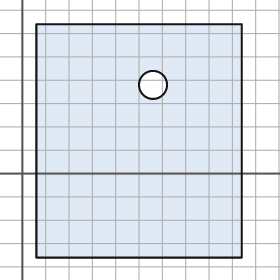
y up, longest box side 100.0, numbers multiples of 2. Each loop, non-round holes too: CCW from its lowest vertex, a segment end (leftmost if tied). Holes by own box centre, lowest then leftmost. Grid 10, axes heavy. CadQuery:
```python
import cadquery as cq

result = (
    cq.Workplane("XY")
    .moveTo(6.0, -36.0)
    .lineTo(94.0, -36.0)
    .lineTo(94.0, 64.0)
    .lineTo(6.0, 64.0)
    .close()
    .moveTo(56.0, 38.0)
    .circle(6.0)
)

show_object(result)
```